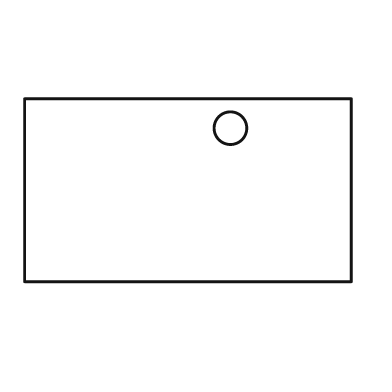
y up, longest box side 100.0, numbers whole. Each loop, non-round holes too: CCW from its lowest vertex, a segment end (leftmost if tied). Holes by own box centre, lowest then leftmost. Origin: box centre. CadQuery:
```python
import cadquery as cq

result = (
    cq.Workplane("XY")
    .moveTo(-50.0, -28.0)
    .lineTo(50.0, -28.0)
    .lineTo(50.0, 28.0)
    .lineTo(-50.0, 28.0)
    .close()
    .moveTo(13.0, 19.0)
    .circle(5.0)
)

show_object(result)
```